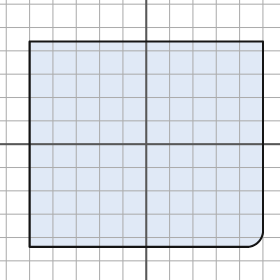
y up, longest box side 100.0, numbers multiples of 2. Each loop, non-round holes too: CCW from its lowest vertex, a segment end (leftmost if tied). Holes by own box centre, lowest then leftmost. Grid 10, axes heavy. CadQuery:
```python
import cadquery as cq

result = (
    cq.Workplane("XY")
    .moveTo(-50.0, -44.0)
    .lineTo(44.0, -44.0)
    .threePointArc((48.0, -42.0), (50.0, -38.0))
    .lineTo(50.0, 44.0)
    .lineTo(-50.0, 44.0)
    .close()
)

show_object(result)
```